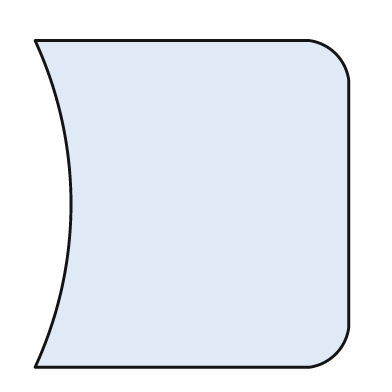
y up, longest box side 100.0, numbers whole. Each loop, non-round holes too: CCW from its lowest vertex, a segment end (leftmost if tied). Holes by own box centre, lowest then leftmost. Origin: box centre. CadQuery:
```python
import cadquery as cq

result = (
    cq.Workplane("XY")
    .moveTo(-48.0, -50.0)
    .lineTo(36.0, -50.0)
    .threePointArc((44.0, -46.0), (48.0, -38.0))
    .lineTo(48.0, 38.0)
    .threePointArc((44.0, 46.0), (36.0, 50.0))
    .lineTo(-48.0, 50.0)
    .threePointArc((-37.0, 0.0), (-48.0, -50.0))
    .close()
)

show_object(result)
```